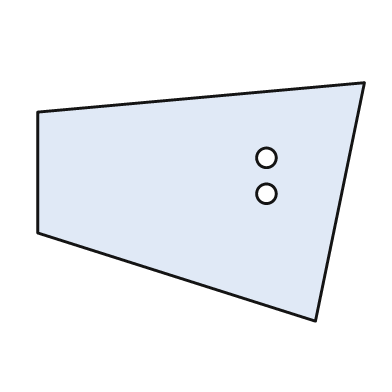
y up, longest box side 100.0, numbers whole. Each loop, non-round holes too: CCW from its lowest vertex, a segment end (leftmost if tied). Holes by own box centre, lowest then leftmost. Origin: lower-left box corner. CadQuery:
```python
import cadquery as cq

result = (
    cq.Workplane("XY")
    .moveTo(85.0, 0.0)
    .lineTo(100.0, 73.0)
    .lineTo(0.0, 64.0)
    .lineTo(0.0, 27.0)
    .close()
    .moveTo(70.0, 39.0)
    .circle(3.0)
    .moveTo(70.0, 50.0)
    .circle(3.0)
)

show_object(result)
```